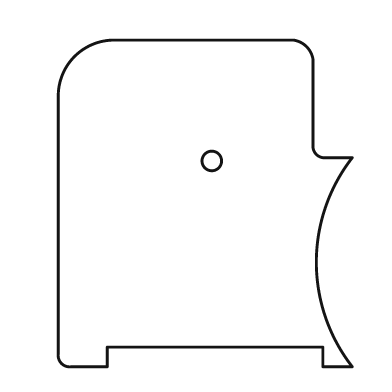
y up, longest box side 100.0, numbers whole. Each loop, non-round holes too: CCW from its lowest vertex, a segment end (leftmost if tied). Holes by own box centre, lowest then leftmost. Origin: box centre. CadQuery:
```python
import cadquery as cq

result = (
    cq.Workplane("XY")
    .moveTo(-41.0, -50.0)
    .lineTo(-30.0, -50.0)
    .lineTo(-30.0, -44.0)
    .lineTo(36.0, -44.0)
    .lineTo(36.0, -50.0)
    .lineTo(45.0, -50.0)
    .threePointArc((34.0, -18.0), (45.0, 14.0))
    .lineTo(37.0, 14.0)
    .threePointArc((34.0, 15.0), (33.0, 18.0))
    .lineTo(33.0, 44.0)
    .threePointArc((31.0, 48.0), (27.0, 50.0))
    .lineTo(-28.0, 50.0)
    .threePointArc((-40.0, 45.0), (-45.0, 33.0))
    .lineTo(-45.0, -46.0)
    .threePointArc((-44.0, -49.0), (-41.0, -50.0))
    .close()
    .moveTo(2.0, 13.0)
    .circle(3.0)
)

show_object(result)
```